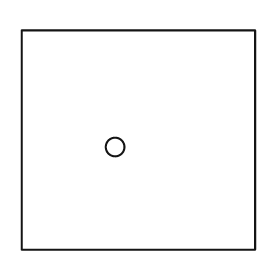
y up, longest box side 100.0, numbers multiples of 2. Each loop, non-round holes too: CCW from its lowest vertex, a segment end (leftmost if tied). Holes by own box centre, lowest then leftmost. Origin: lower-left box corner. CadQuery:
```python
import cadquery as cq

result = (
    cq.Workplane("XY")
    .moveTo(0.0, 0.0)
    .lineTo(100.0, 0.0)
    .lineTo(100.0, 94.0)
    .lineTo(0.0, 94.0)
    .close()
    .moveTo(40.0, 44.0)
    .circle(4.0)
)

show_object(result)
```